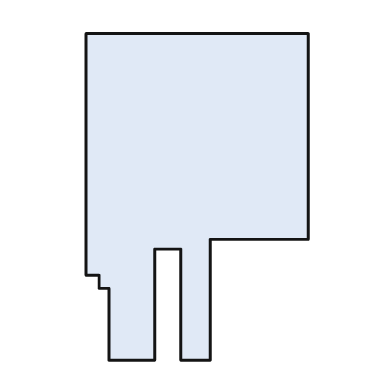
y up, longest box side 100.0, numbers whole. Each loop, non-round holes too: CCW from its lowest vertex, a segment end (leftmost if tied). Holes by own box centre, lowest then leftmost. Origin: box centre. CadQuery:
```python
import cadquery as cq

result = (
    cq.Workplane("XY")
    .moveTo(-27.0, -50.0)
    .lineTo(-13.0, -50.0)
    .lineTo(-13.0, -16.0)
    .lineTo(-5.0, -16.0)
    .lineTo(-5.0, -50.0)
    .lineTo(4.0, -50.0)
    .lineTo(4.0, -13.0)
    .lineTo(34.0, -13.0)
    .lineTo(34.0, 50.0)
    .lineTo(-34.0, 50.0)
    .lineTo(-34.0, -24.0)
    .lineTo(-30.0, -24.0)
    .lineTo(-30.0, -28.0)
    .lineTo(-27.0, -28.0)
    .close()
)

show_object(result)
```